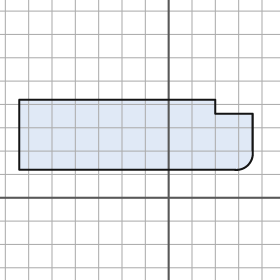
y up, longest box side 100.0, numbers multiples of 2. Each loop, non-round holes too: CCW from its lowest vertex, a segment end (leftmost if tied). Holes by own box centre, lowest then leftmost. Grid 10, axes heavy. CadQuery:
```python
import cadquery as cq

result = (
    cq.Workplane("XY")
    .moveTo(-64.0, 12.0)
    .lineTo(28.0, 12.0)
    .threePointArc((34.0, 14.0), (36.0, 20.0))
    .lineTo(36.0, 36.0)
    .lineTo(20.0, 36.0)
    .lineTo(20.0, 42.0)
    .lineTo(-64.0, 42.0)
    .close()
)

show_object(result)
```